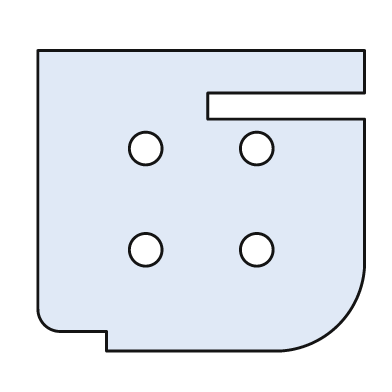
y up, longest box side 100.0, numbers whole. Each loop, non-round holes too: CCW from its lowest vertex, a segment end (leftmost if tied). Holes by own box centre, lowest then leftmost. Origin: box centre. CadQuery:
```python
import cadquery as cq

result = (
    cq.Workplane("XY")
    .moveTo(-29.0, -46.0)
    .lineTo(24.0, -46.0)
    .threePointArc((42.0, -38.0), (50.0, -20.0))
    .lineTo(50.0, 25.0)
    .lineTo(2.0, 25.0)
    .lineTo(2.0, 33.0)
    .lineTo(50.0, 33.0)
    .lineTo(50.0, 46.0)
    .lineTo(-50.0, 46.0)
    .lineTo(-50.0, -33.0)
    .threePointArc((-48.0, -38.0), (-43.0, -40.0))
    .lineTo(-29.0, -40.0)
    .close()
    .moveTo(-17.0, -15.0)
    .circle(5.0)
    .moveTo(17.0, -15.0)
    .circle(5.0)
    .moveTo(-17.0, 16.0)
    .circle(5.0)
    .moveTo(17.0, 16.0)
    .circle(5.0)
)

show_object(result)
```